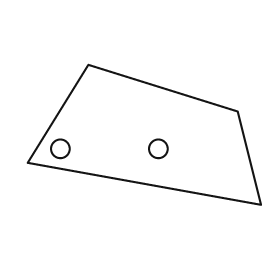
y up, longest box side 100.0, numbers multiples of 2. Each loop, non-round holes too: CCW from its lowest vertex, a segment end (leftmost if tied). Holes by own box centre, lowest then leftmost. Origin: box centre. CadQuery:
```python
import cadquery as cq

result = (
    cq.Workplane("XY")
    .moveTo(50.0, -30.0)
    .lineTo(40.0, 10.0)
    .lineTo(-24.0, 30.0)
    .lineTo(-50.0, -12.0)
    .close()
    .moveTo(-36.0, -6.0)
    .circle(4.0)
    .moveTo(6.0, -6.0)
    .circle(4.0)
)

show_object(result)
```